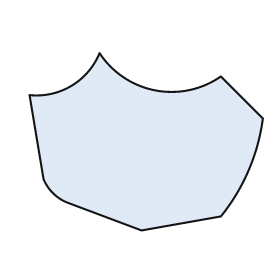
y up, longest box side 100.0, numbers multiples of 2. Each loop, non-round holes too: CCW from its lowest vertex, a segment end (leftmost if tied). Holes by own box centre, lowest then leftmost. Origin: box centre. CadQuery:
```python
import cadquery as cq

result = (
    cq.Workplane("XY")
    .moveTo(-2.0, -38.0)
    .lineTo(32.0, -32.0)
    .threePointArc((44.0, -12.0), (50.0, 10.0))
    .lineTo(32.0, 28.0)
    .threePointArc((4.0, 22.0), (-20.0, 38.0))
    .threePointArc((-32.0, 24.0), (-50.0, 20.0))
    .lineTo(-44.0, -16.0)
    .threePointArc((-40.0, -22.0), (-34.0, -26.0))
    .close()
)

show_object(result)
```